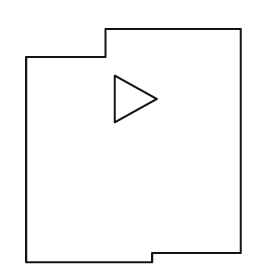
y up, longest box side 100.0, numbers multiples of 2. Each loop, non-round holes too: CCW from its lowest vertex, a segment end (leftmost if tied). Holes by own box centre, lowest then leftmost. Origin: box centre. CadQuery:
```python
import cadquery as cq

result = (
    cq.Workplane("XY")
    .moveTo(-46.0, -50.0)
    .lineTo(8.0, -50.0)
    .lineTo(8.0, -46.0)
    .lineTo(46.0, -46.0)
    .lineTo(46.0, 50.0)
    .lineTo(-12.0, 50.0)
    .lineTo(-12.0, 38.0)
    .lineTo(-46.0, 38.0)
    .close()
    .moveTo(-8.0, 10.0)
    .lineTo(10.0, 20.0)
    .lineTo(-8.0, 30.0)
    .close()
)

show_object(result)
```